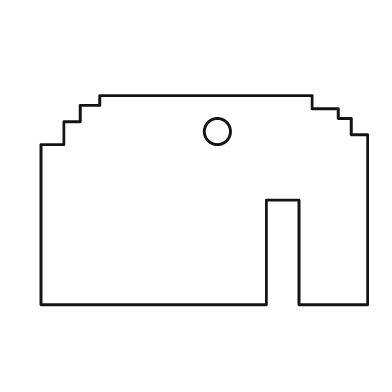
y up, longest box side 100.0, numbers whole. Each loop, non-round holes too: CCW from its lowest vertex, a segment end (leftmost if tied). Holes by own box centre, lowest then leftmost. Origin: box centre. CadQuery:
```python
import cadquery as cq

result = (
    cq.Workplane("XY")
    .moveTo(-50.0, -32.0)
    .lineTo(19.0, -32.0)
    .lineTo(19.0, 0.0)
    .lineTo(29.0, 0.0)
    .lineTo(29.0, -32.0)
    .lineTo(50.0, -32.0)
    .lineTo(50.0, 20.0)
    .lineTo(45.0, 20.0)
    .lineTo(45.0, 25.0)
    .lineTo(41.0, 25.0)
    .lineTo(41.0, 28.0)
    .lineTo(33.0, 28.0)
    .lineTo(33.0, 32.0)
    .lineTo(-32.0, 32.0)
    .lineTo(-32.0, 29.0)
    .lineTo(-38.0, 29.0)
    .lineTo(-38.0, 24.0)
    .lineTo(-43.0, 24.0)
    .lineTo(-43.0, 17.0)
    .lineTo(-50.0, 17.0)
    .close()
    .moveTo(4.0, 21.0)
    .circle(4.0)
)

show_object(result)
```